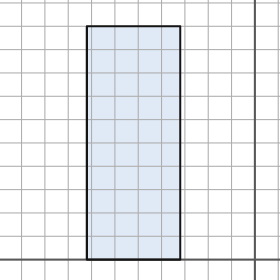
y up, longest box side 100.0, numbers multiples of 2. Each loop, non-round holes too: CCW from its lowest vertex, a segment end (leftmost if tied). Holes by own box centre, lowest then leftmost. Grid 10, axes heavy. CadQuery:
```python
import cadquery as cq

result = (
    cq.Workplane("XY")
    .moveTo(-72.0, 0.0)
    .lineTo(-32.0, 0.0)
    .lineTo(-32.0, 100.0)
    .lineTo(-72.0, 100.0)
    .close()
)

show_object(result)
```